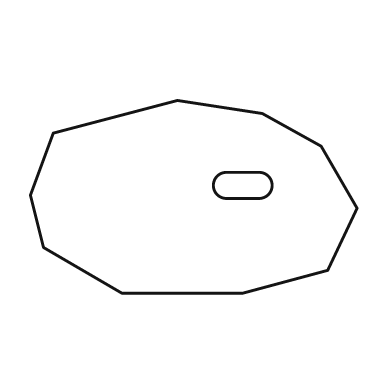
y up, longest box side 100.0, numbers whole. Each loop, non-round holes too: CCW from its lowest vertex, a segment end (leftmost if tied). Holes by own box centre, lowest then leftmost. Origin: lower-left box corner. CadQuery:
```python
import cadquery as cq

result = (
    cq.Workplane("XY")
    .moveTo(28.0, 0.0)
    .lineTo(65.0, 0.0)
    .lineTo(91.0, 7.0)
    .lineTo(100.0, 26.0)
    .lineTo(89.0, 45.0)
    .lineTo(71.0, 55.0)
    .lineTo(45.0, 59.0)
    .lineTo(7.0, 49.0)
    .lineTo(0.0, 30.0)
    .lineTo(4.0, 14.0)
    .close()
    .moveTo(60.0, 29.0)
    .lineTo(70.0, 29.0)
    .threePointArc((74.0, 33.0), (70.0, 37.0))
    .lineTo(60.0, 37.0)
    .threePointArc((56.0, 33.0), (60.0, 29.0))
    .close()
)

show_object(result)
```